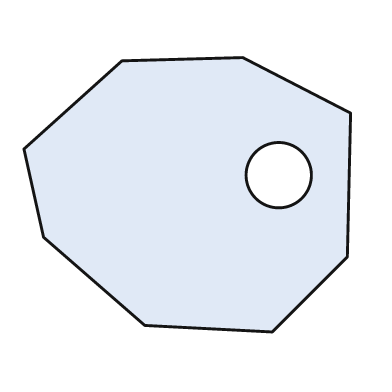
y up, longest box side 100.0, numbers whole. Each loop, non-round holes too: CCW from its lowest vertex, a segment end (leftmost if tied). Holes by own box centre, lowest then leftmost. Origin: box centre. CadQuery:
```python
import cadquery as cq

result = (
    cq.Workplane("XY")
    .moveTo(26.0, -42.0)
    .lineTo(49.0, -19.0)
    .lineTo(50.0, 25.0)
    .lineTo(17.0, 42.0)
    .lineTo(-20.0, 41.0)
    .lineTo(-50.0, 14.0)
    .lineTo(-44.0, -13.0)
    .lineTo(-13.0, -40.0)
    .close()
    .moveTo(28.0, 6.0)
    .circle(10.0)
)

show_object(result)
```